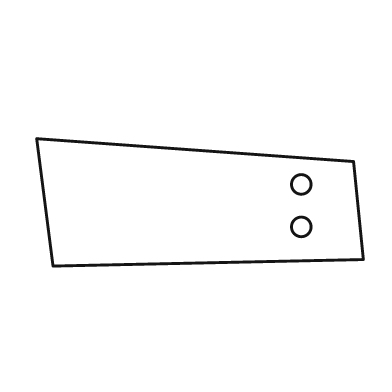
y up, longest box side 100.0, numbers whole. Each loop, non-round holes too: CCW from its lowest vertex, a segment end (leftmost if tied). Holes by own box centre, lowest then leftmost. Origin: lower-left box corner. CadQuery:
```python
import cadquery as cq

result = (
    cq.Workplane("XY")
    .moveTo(5.0, 0.0)
    .lineTo(100.0, 2.0)
    .lineTo(97.0, 32.0)
    .lineTo(0.0, 39.0)
    .close()
    .moveTo(81.0, 12.0)
    .circle(3.0)
    .moveTo(81.0, 25.0)
    .circle(3.0)
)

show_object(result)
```